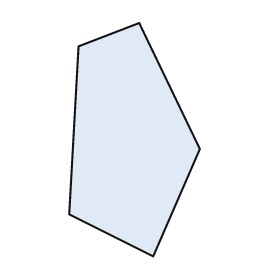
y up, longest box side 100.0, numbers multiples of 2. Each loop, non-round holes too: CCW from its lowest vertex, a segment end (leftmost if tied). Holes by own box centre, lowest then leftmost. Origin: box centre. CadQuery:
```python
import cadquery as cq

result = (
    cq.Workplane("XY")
    .moveTo(8.0, -50.0)
    .lineTo(28.0, -4.0)
    .lineTo(2.0, 50.0)
    .lineTo(-24.0, 40.0)
    .lineTo(-28.0, -32.0)
    .close()
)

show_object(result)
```